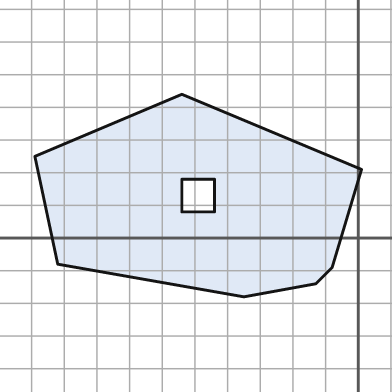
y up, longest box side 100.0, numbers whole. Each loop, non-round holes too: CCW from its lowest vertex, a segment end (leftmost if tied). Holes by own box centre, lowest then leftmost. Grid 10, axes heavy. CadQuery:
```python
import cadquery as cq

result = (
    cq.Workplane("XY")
    .moveTo(-35.0, -18.0)
    .lineTo(-13.0, -14.0)
    .lineTo(-8.0, -9.0)
    .lineTo(1.0, 21.0)
    .lineTo(-54.0, 44.0)
    .lineTo(-99.0, 25.0)
    .lineTo(-92.0, -8.0)
    .close()
    .moveTo(-54.0, 8.0)
    .lineTo(-44.0, 8.0)
    .lineTo(-44.0, 18.0)
    .lineTo(-54.0, 18.0)
    .close()
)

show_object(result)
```